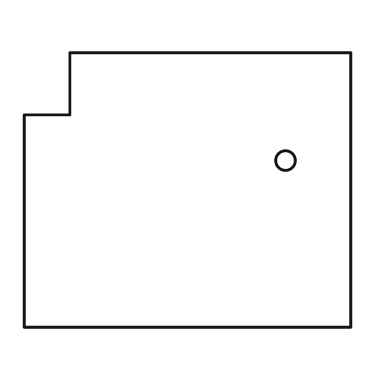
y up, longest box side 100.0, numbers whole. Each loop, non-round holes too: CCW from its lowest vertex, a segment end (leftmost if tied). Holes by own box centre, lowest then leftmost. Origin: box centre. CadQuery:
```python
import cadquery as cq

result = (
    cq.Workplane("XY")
    .moveTo(-50.0, -42.0)
    .lineTo(50.0, -42.0)
    .lineTo(50.0, 42.0)
    .lineTo(-36.0, 42.0)
    .lineTo(-36.0, 23.0)
    .lineTo(-50.0, 23.0)
    .close()
    .moveTo(30.0, 9.0)
    .circle(3.0)
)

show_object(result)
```